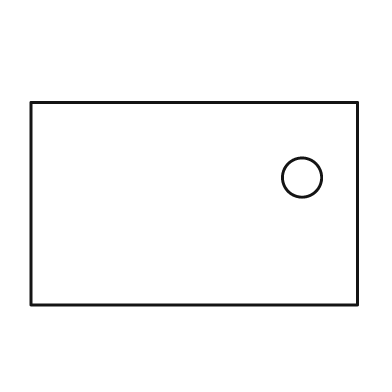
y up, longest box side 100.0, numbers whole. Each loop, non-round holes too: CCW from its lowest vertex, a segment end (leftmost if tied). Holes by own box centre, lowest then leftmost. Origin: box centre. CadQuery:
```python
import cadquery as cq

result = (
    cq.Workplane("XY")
    .moveTo(-50.0, -31.0)
    .lineTo(50.0, -31.0)
    .lineTo(50.0, 31.0)
    .lineTo(-50.0, 31.0)
    .close()
    .moveTo(33.0, 8.0)
    .circle(6.0)
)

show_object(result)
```